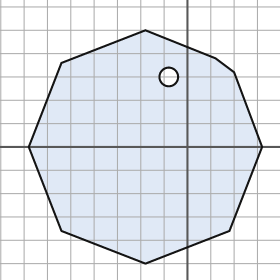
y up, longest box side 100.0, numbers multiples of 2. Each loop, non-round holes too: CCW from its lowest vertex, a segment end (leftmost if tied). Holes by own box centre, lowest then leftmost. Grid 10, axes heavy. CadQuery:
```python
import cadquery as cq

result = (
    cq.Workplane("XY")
    .moveTo(-18.0, -50.0)
    .lineTo(18.0, -36.0)
    .lineTo(32.0, 0.0)
    .lineTo(20.0, 32.0)
    .lineTo(12.0, 38.0)
    .lineTo(-18.0, 50.0)
    .lineTo(-54.0, 36.0)
    .lineTo(-68.0, 0.0)
    .lineTo(-54.0, -36.0)
    .close()
    .moveTo(-8.0, 30.0)
    .circle(4.0)
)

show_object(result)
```